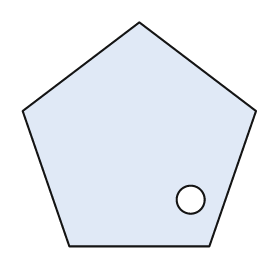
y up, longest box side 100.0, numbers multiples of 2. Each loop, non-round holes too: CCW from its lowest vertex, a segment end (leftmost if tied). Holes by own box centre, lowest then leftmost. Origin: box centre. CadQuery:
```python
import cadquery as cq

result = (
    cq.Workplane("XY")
    .moveTo(-30.0, -48.0)
    .lineTo(30.0, -48.0)
    .lineTo(50.0, 10.0)
    .lineTo(0.0, 48.0)
    .lineTo(-50.0, 10.0)
    .close()
    .moveTo(22.0, -28.0)
    .circle(6.0)
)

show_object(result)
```